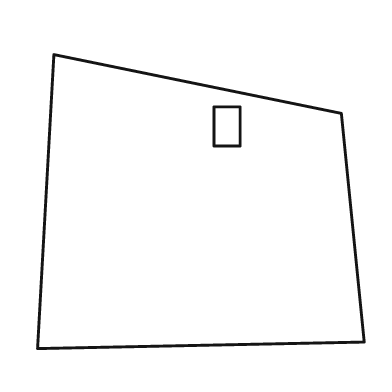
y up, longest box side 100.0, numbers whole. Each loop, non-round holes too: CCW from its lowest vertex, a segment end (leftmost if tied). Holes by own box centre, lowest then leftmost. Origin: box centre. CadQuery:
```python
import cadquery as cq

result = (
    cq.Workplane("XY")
    .moveTo(-50.0, -45.0)
    .lineTo(50.0, -43.0)
    .lineTo(43.0, 27.0)
    .lineTo(-45.0, 45.0)
    .close()
    .moveTo(4.0, 17.0)
    .lineTo(12.0, 17.0)
    .lineTo(12.0, 29.0)
    .lineTo(4.0, 29.0)
    .close()
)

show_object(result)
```